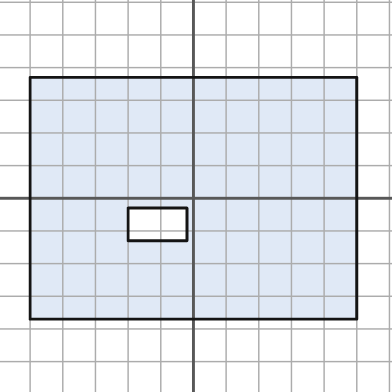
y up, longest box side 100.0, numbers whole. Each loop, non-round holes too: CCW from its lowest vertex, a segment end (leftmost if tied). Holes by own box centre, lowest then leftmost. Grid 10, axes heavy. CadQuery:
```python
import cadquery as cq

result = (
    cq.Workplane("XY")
    .moveTo(-50.0, -37.0)
    .lineTo(50.0, -37.0)
    .lineTo(50.0, 37.0)
    .lineTo(-50.0, 37.0)
    .close()
    .moveTo(-20.0, -13.0)
    .lineTo(-2.0, -13.0)
    .lineTo(-2.0, -3.0)
    .lineTo(-20.0, -3.0)
    .close()
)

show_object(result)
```